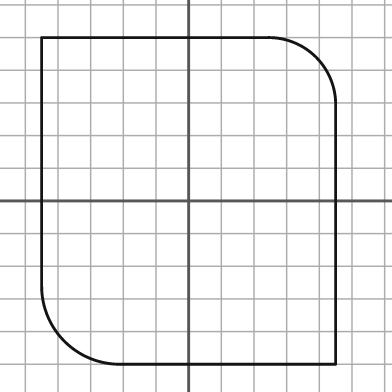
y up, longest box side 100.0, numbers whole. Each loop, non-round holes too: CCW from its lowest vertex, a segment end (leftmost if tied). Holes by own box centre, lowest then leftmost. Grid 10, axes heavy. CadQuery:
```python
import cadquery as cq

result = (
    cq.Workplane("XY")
    .moveTo(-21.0, -50.0)
    .lineTo(45.0, -50.0)
    .lineTo(45.0, 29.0)
    .threePointArc((39.0, 44.0), (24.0, 50.0))
    .lineTo(-45.0, 50.0)
    .lineTo(-45.0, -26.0)
    .threePointArc((-38.0, -43.0), (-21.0, -50.0))
    .close()
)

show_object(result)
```